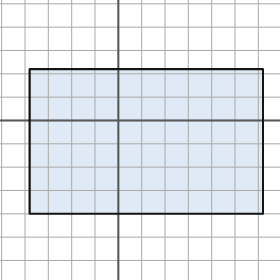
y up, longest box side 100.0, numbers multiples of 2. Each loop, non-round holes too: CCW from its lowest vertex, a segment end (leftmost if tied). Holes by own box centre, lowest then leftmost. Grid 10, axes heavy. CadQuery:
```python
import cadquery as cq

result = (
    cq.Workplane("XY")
    .moveTo(-38.0, -40.0)
    .lineTo(62.0, -40.0)
    .lineTo(62.0, 22.0)
    .lineTo(-38.0, 22.0)
    .close()
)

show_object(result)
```